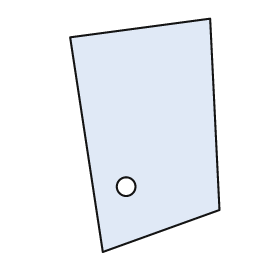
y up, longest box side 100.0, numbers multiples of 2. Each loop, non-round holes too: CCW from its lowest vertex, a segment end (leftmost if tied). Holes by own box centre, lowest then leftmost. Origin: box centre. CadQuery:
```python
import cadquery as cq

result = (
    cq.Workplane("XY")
    .moveTo(-18.0, -50.0)
    .lineTo(32.0, -32.0)
    .lineTo(28.0, 50.0)
    .lineTo(-32.0, 42.0)
    .close()
    .moveTo(-8.0, -22.0)
    .circle(4.0)
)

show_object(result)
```